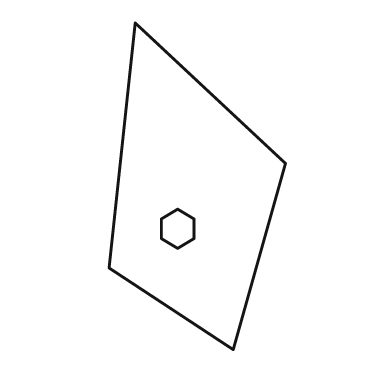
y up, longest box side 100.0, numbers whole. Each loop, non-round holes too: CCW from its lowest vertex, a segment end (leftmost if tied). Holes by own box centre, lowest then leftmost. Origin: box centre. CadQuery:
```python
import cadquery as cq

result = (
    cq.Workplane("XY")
    .moveTo(11.0, -50.0)
    .lineTo(27.0, 7.0)
    .lineTo(-19.0, 50.0)
    .lineTo(-27.0, -25.0)
    .close()
    .moveTo(-6.0, -19.0)
    .lineTo(-1.0, -16.0)
    .lineTo(-1.0, -10.0)
    .lineTo(-6.0, -7.0)
    .lineTo(-11.0, -10.0)
    .lineTo(-11.0, -16.0)
    .close()
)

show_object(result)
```